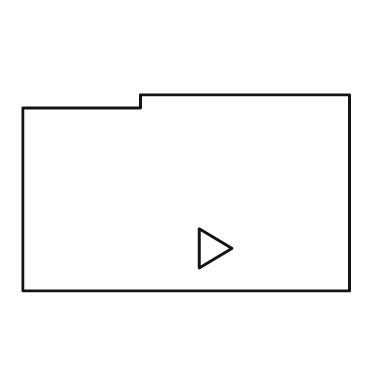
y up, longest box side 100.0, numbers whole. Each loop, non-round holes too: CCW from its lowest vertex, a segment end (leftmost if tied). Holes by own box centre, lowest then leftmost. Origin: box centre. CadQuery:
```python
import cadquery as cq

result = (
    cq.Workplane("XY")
    .moveTo(-50.0, -30.0)
    .lineTo(50.0, -30.0)
    .lineTo(50.0, 30.0)
    .lineTo(-14.0, 30.0)
    .lineTo(-14.0, 26.0)
    .lineTo(-50.0, 26.0)
    .close()
    .moveTo(4.0, -23.0)
    .lineTo(14.0, -17.0)
    .lineTo(4.0, -11.0)
    .close()
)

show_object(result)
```